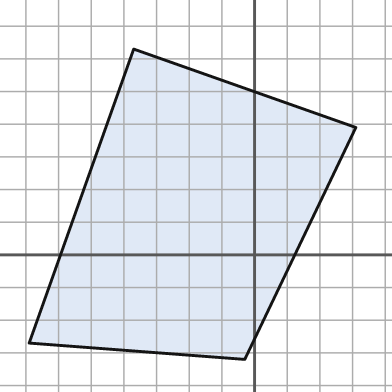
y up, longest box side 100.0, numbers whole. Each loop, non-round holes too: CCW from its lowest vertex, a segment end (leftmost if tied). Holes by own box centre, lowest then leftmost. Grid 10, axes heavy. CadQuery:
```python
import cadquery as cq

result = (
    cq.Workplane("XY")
    .moveTo(-3.0, -32.0)
    .lineTo(31.0, 39.0)
    .lineTo(-37.0, 63.0)
    .lineTo(-69.0, -27.0)
    .close()
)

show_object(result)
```